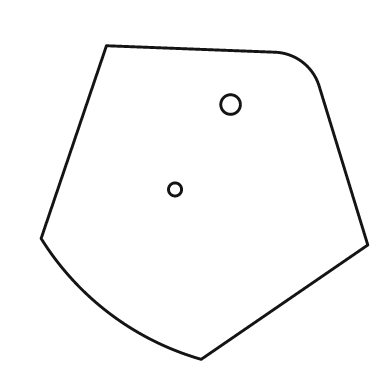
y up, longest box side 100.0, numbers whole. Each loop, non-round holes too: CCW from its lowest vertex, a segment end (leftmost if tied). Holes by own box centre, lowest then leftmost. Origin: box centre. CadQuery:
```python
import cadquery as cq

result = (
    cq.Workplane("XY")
    .moveTo(-1.0, -48.0)
    .lineTo(50.0, -13.0)
    .lineTo(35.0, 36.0)
    .threePointArc((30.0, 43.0), (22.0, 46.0))
    .lineTo(-30.0, 48.0)
    .lineTo(-50.0, -11.0)
    .threePointArc((-29.0, -34.0), (-1.0, -48.0))
    .close()
    .moveTo(-9.0, 4.0)
    .circle(2.0)
    .moveTo(8.0, 30.0)
    .circle(3.0)
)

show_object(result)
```